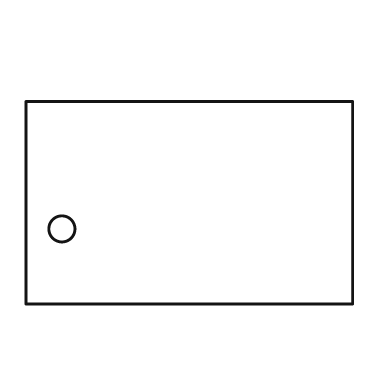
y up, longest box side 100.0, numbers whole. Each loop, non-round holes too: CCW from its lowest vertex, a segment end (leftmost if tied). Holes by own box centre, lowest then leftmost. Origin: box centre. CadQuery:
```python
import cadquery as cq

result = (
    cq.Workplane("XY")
    .moveTo(-50.0, -31.0)
    .lineTo(50.0, -31.0)
    .lineTo(50.0, 31.0)
    .lineTo(-50.0, 31.0)
    .close()
    .moveTo(-39.0, -8.0)
    .circle(4.0)
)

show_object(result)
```